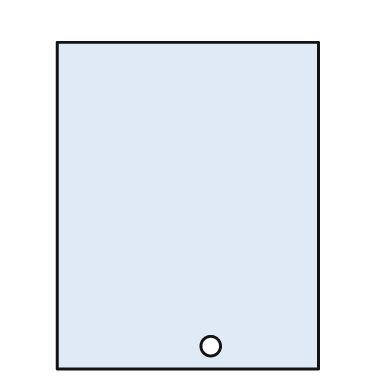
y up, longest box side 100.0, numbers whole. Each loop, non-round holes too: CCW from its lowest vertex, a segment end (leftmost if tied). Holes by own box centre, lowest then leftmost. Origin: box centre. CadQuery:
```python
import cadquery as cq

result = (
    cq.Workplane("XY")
    .moveTo(-40.0, -50.0)
    .lineTo(40.0, -50.0)
    .lineTo(40.0, 50.0)
    .lineTo(-40.0, 50.0)
    .close()
    .moveTo(7.0, -43.0)
    .circle(3.0)
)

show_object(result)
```